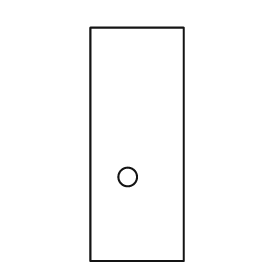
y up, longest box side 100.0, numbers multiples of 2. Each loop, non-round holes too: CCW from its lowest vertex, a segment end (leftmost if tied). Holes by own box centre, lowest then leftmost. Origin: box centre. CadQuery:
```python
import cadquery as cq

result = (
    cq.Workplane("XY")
    .moveTo(-20.0, -50.0)
    .lineTo(20.0, -50.0)
    .lineTo(20.0, 50.0)
    .lineTo(-20.0, 50.0)
    .close()
    .moveTo(-4.0, -14.0)
    .circle(4.0)
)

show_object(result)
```